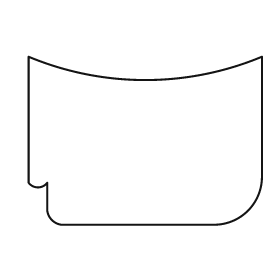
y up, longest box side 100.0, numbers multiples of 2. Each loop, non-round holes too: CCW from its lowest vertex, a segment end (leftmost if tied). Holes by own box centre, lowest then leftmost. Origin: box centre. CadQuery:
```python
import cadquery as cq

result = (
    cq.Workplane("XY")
    .moveTo(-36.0, -36.0)
    .lineTo(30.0, -36.0)
    .threePointArc((44.0, -30.0), (50.0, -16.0))
    .lineTo(50.0, 36.0)
    .threePointArc((0.0, 26.0), (-50.0, 36.0))
    .lineTo(-50.0, -18.0)
    .threePointArc((-46.0, -20.0), (-42.0, -18.0))
    .lineTo(-42.0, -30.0)
    .threePointArc((-40.0, -34.0), (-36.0, -36.0))
    .close()
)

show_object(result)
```